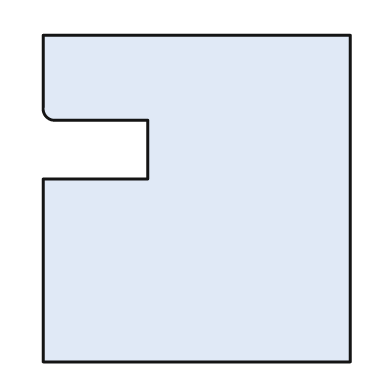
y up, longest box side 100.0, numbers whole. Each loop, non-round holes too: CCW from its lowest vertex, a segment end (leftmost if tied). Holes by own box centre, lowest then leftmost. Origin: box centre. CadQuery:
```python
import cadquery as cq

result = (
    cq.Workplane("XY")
    .moveTo(-47.0, -50.0)
    .lineTo(47.0, -50.0)
    .lineTo(47.0, 50.0)
    .lineTo(-47.0, 50.0)
    .lineTo(-47.0, 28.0)
    .threePointArc((-46.0, 25.0), (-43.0, 24.0))
    .lineTo(-15.0, 24.0)
    .lineTo(-15.0, 6.0)
    .lineTo(-47.0, 6.0)
    .close()
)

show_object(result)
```